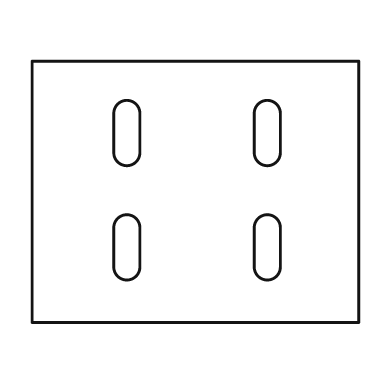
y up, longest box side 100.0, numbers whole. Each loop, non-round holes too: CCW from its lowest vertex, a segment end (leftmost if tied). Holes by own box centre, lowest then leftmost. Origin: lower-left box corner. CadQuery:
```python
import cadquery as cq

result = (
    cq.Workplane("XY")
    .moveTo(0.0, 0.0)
    .lineTo(100.0, 0.0)
    .lineTo(100.0, 80.0)
    .lineTo(0.0, 80.0)
    .close()
    .moveTo(25.0, 17.0)
    .threePointArc((29.0, 13.0), (33.0, 17.0))
    .lineTo(33.0, 29.0)
    .threePointArc((29.0, 33.0), (25.0, 29.0))
    .close()
    .moveTo(68.0, 17.0)
    .threePointArc((72.0, 13.0), (76.0, 17.0))
    .lineTo(76.0, 29.0)
    .threePointArc((72.0, 33.0), (68.0, 29.0))
    .close()
    .moveTo(25.0, 52.0)
    .threePointArc((29.0, 48.0), (33.0, 52.0))
    .lineTo(33.0, 64.0)
    .threePointArc((29.0, 68.0), (25.0, 64.0))
    .close()
    .moveTo(68.0, 52.0)
    .threePointArc((72.0, 48.0), (76.0, 52.0))
    .lineTo(76.0, 64.0)
    .threePointArc((72.0, 68.0), (68.0, 64.0))
    .close()
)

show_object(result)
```